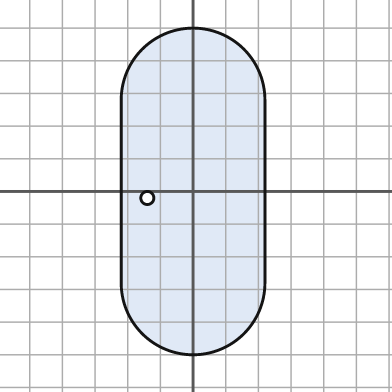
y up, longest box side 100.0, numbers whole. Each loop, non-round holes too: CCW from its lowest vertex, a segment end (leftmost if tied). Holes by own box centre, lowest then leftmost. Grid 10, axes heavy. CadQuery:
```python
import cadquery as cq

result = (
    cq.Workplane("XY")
    .moveTo(-22.0, -28.0)
    .threePointArc((0.0, -50.0), (22.0, -28.0))
    .lineTo(22.0, 28.0)
    .threePointArc((0.0, 50.0), (-22.0, 28.0))
    .close()
    .moveTo(-14.0, -2.0)
    .circle(2.0)
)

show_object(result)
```